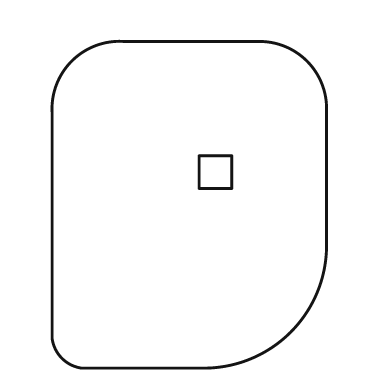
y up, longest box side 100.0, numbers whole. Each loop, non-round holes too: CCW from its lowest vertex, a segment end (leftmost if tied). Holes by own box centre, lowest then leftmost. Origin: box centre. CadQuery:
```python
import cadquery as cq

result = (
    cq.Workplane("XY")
    .moveTo(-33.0, -50.0)
    .lineTo(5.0, -50.0)
    .threePointArc((31.0, -39.0), (42.0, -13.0))
    .lineTo(42.0, 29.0)
    .threePointArc((36.0, 44.0), (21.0, 50.0))
    .lineTo(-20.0, 50.0)
    .threePointArc((-36.0, 44.0), (-42.0, 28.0))
    .lineTo(-42.0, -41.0)
    .threePointArc((-39.0, -47.0), (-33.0, -50.0))
    .close()
    .moveTo(3.0, 5.0)
    .lineTo(13.0, 5.0)
    .lineTo(13.0, 15.0)
    .lineTo(3.0, 15.0)
    .close()
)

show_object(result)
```